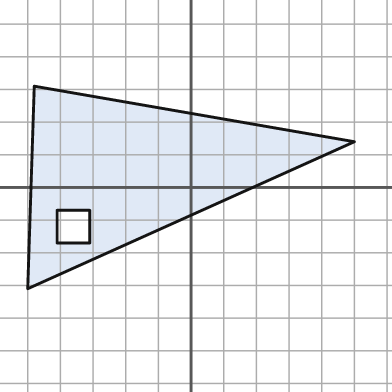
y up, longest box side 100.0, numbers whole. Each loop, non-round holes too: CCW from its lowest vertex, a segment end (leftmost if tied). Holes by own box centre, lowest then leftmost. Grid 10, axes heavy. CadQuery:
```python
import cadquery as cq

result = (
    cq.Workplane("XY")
    .moveTo(-50.0, -31.0)
    .lineTo(50.0, 14.0)
    .lineTo(-48.0, 31.0)
    .close()
    .moveTo(-41.0, -17.0)
    .lineTo(-31.0, -17.0)
    .lineTo(-31.0, -7.0)
    .lineTo(-41.0, -7.0)
    .close()
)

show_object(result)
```